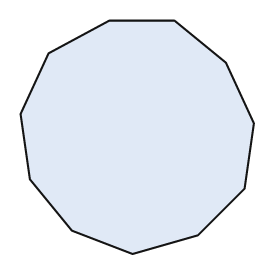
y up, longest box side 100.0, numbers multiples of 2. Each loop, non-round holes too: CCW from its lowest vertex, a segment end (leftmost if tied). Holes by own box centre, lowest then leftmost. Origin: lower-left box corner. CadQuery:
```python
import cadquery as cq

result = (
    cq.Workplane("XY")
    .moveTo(48.0, 0.0)
    .lineTo(76.0, 8.0)
    .lineTo(96.0, 28.0)
    .lineTo(100.0, 56.0)
    .lineTo(88.0, 82.0)
    .lineTo(66.0, 100.0)
    .lineTo(38.0, 100.0)
    .lineTo(12.0, 86.0)
    .lineTo(0.0, 60.0)
    .lineTo(4.0, 32.0)
    .lineTo(22.0, 10.0)
    .close()
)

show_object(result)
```